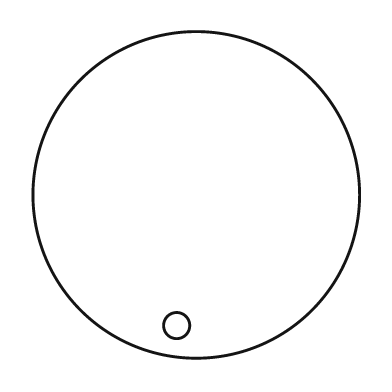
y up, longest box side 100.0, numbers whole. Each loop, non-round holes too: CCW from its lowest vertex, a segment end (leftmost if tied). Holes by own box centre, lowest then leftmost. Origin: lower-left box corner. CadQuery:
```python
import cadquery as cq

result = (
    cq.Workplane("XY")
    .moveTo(50.0, 50.0)
    .circle(50.0)
    .moveTo(44.0, 10.0)
    .circle(4.0)
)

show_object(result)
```